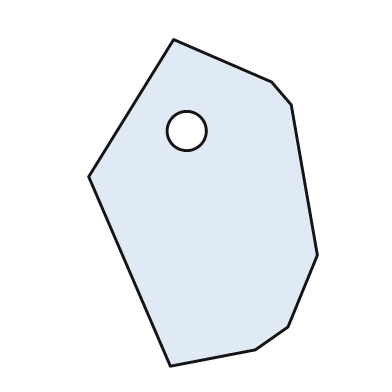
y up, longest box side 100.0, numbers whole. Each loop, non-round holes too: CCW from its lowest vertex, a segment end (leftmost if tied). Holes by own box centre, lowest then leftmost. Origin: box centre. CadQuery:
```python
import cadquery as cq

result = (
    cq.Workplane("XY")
    .moveTo(-10.0, -50.0)
    .lineTo(16.0, -45.0)
    .lineTo(26.0, -38.0)
    .lineTo(35.0, -16.0)
    .lineTo(27.0, 30.0)
    .lineTo(21.0, 37.0)
    .lineTo(-9.0, 50.0)
    .lineTo(-35.0, 8.0)
    .close()
    .moveTo(-5.0, 22.0)
    .circle(6.0)
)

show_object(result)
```